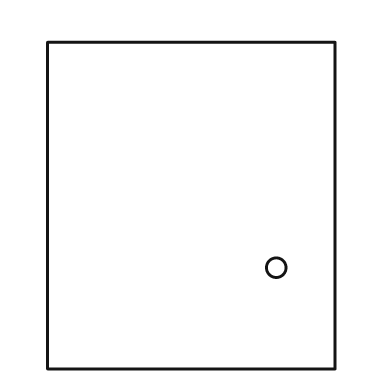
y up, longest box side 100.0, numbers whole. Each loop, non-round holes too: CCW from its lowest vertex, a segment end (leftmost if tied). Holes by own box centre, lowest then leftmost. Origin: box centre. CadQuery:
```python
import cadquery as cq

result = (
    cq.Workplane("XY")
    .moveTo(-44.0, -50.0)
    .lineTo(44.0, -50.0)
    .lineTo(44.0, 50.0)
    .lineTo(-44.0, 50.0)
    .close()
    .moveTo(26.0, -19.0)
    .circle(3.0)
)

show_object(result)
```